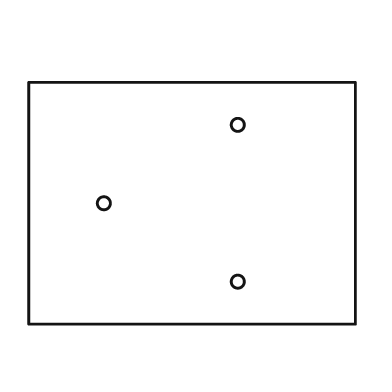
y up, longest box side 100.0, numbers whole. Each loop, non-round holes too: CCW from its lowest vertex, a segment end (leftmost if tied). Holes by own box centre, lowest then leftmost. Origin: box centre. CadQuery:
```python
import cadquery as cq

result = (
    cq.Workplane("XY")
    .moveTo(-50.0, -37.0)
    .lineTo(50.0, -37.0)
    .lineTo(50.0, 37.0)
    .lineTo(-50.0, 37.0)
    .close()
    .moveTo(14.0, -24.0)
    .circle(2.0)
    .moveTo(-27.0, 0.0)
    .circle(2.0)
    .moveTo(14.0, 24.0)
    .circle(2.0)
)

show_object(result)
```